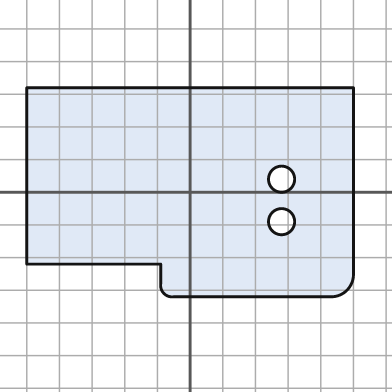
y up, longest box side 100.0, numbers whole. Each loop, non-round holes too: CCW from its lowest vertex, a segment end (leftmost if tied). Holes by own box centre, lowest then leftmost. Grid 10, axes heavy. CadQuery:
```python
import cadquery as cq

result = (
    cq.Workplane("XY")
    .moveTo(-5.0, -32.0)
    .lineTo(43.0, -32.0)
    .threePointArc((48.0, -30.0), (50.0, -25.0))
    .lineTo(50.0, 32.0)
    .lineTo(-50.0, 32.0)
    .lineTo(-50.0, -22.0)
    .lineTo(-9.0, -22.0)
    .lineTo(-9.0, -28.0)
    .threePointArc((-8.0, -31.0), (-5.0, -32.0))
    .close()
    .moveTo(28.0, -9.0)
    .circle(4.0)
    .moveTo(28.0, 4.0)
    .circle(4.0)
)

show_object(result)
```